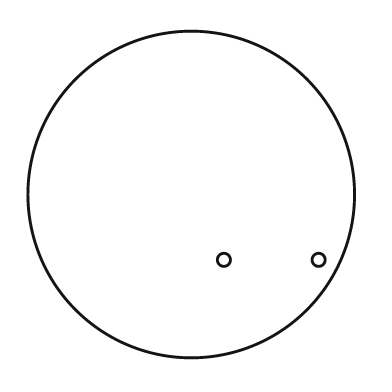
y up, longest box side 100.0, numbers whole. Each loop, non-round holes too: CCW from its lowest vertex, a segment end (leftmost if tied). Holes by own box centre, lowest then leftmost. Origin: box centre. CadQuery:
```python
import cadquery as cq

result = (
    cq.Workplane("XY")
    .moveTo(0.0, 0.0)
    .circle(50.0)
    .moveTo(10.0, -20.0)
    .circle(2.0)
    .moveTo(39.0, -20.0)
    .circle(2.0)
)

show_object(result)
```